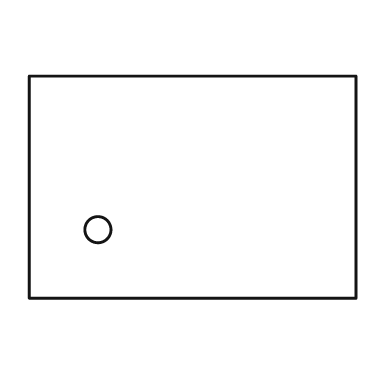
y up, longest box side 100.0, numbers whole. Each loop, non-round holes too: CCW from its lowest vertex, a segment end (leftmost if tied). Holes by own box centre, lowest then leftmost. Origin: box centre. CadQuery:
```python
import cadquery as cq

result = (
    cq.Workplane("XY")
    .moveTo(-50.0, -34.0)
    .lineTo(50.0, -34.0)
    .lineTo(50.0, 34.0)
    .lineTo(-50.0, 34.0)
    .close()
    .moveTo(-29.0, -13.0)
    .circle(4.0)
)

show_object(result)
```